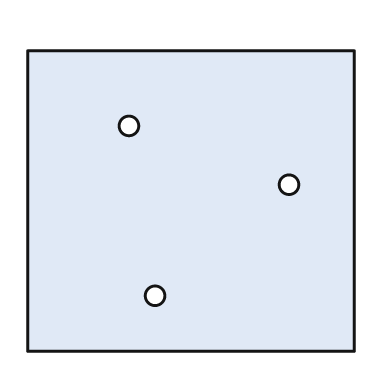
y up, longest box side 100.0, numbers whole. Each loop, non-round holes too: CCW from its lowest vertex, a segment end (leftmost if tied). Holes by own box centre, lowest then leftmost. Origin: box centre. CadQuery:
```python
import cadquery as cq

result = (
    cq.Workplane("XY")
    .moveTo(-50.0, -46.0)
    .lineTo(50.0, -46.0)
    .lineTo(50.0, 46.0)
    .lineTo(-50.0, 46.0)
    .close()
    .moveTo(-11.0, -29.0)
    .circle(3.0)
    .moveTo(30.0, 5.0)
    .circle(3.0)
    .moveTo(-19.0, 23.0)
    .circle(3.0)
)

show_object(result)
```